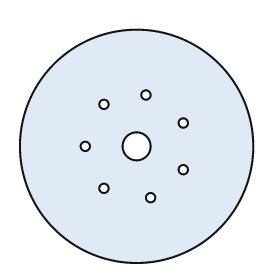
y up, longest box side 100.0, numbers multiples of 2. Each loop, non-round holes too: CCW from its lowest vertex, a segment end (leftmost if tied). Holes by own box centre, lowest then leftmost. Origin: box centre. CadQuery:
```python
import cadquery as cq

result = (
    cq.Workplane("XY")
    .moveTo(0.0, 0.0)
    .circle(50.0)
    .moveTo(6.0, -22.0)
    .circle(2.0)
    .moveTo(-14.0, -18.0)
    .circle(2.0)
    .moveTo(20.0, -10.0)
    .circle(2.0)
    .moveTo(-22.0, 0.0)
    .circle(2.0)
    .moveTo(0.0, 0.0)
    .circle(6.0)
    .moveTo(20.0, 10.0)
    .circle(2.0)
    .moveTo(-14.0, 18.0)
    .circle(2.0)
    .moveTo(4.0, 22.0)
    .circle(2.0)
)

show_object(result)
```